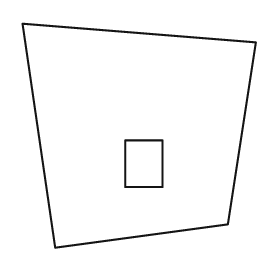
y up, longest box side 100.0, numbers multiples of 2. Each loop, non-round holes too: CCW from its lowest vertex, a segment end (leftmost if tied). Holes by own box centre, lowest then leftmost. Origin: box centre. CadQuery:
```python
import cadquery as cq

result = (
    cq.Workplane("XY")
    .moveTo(-36.0, -48.0)
    .lineTo(38.0, -38.0)
    .lineTo(50.0, 40.0)
    .lineTo(-50.0, 48.0)
    .close()
    .moveTo(-6.0, -22.0)
    .lineTo(10.0, -22.0)
    .lineTo(10.0, -2.0)
    .lineTo(-6.0, -2.0)
    .close()
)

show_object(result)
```